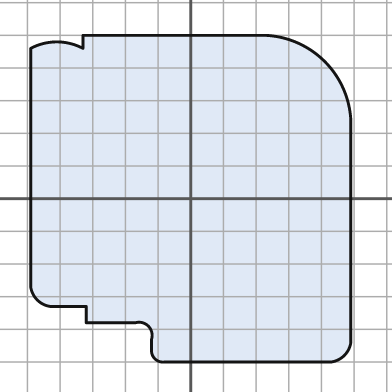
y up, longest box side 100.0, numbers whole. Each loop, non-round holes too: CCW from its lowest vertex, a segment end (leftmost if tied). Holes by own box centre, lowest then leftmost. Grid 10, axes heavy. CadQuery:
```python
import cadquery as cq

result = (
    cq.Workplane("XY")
    .moveTo(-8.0, -50.0)
    .lineTo(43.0, -50.0)
    .threePointArc((47.0, -48.0), (49.0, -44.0))
    .lineTo(49.0, 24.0)
    .threePointArc((41.0, 42.0), (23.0, 50.0))
    .lineTo(-33.0, 50.0)
    .lineTo(-33.0, 46.0)
    .threePointArc((-41.0, 48.0), (-49.0, 46.0))
    .lineTo(-49.0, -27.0)
    .threePointArc((-47.0, -31.0), (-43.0, -33.0))
    .lineTo(-32.0, -33.0)
    .lineTo(-32.0, -38.0)
    .lineTo(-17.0, -38.0)
    .threePointArc((-13.0, -39.0), (-12.0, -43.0))
    .lineTo(-12.0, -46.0)
    .threePointArc((-11.0, -49.0), (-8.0, -50.0))
    .close()
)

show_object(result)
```